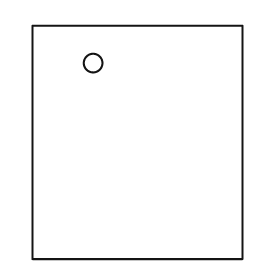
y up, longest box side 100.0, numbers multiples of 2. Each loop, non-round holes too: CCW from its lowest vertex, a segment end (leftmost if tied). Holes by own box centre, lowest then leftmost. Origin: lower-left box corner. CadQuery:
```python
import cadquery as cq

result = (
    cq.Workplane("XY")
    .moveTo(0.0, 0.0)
    .lineTo(90.0, 0.0)
    .lineTo(90.0, 100.0)
    .lineTo(0.0, 100.0)
    .close()
    .moveTo(26.0, 84.0)
    .circle(4.0)
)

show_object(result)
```